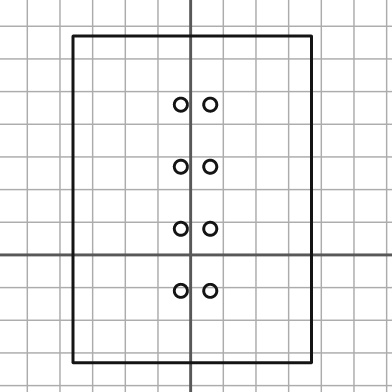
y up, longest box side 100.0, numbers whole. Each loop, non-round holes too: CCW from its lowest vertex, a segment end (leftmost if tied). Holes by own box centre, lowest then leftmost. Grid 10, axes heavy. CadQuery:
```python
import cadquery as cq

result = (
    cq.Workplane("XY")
    .moveTo(-36.0, -33.0)
    .lineTo(37.0, -33.0)
    .lineTo(37.0, 67.0)
    .lineTo(-36.0, 67.0)
    .close()
    .moveTo(-3.0, -11.0)
    .circle(2.0)
    .moveTo(6.0, -11.0)
    .circle(2.0)
    .moveTo(-3.0, 8.0)
    .circle(2.0)
    .moveTo(6.0, 8.0)
    .circle(2.0)
    .moveTo(-3.0, 27.0)
    .circle(2.0)
    .moveTo(6.0, 27.0)
    .circle(2.0)
    .moveTo(-3.0, 46.0)
    .circle(2.0)
    .moveTo(6.0, 46.0)
    .circle(2.0)
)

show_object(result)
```